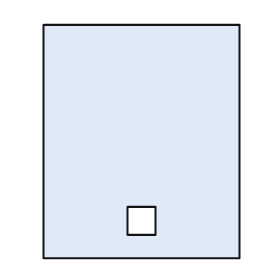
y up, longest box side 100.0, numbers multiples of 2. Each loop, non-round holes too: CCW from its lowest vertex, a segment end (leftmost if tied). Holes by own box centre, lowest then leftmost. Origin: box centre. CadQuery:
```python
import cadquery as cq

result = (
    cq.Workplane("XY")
    .moveTo(-42.0, -50.0)
    .lineTo(42.0, -50.0)
    .lineTo(42.0, 50.0)
    .lineTo(-42.0, 50.0)
    .close()
    .moveTo(-6.0, -40.0)
    .lineTo(6.0, -40.0)
    .lineTo(6.0, -28.0)
    .lineTo(-6.0, -28.0)
    .close()
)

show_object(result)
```